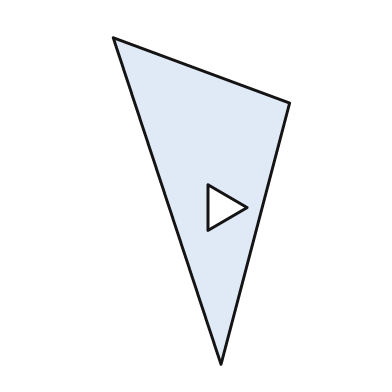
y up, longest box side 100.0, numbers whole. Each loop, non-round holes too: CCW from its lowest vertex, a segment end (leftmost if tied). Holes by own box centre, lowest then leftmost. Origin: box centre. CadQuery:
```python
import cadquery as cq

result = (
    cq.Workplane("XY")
    .moveTo(6.0, -50.0)
    .lineTo(27.0, 30.0)
    .lineTo(-27.0, 50.0)
    .close()
    .moveTo(2.0, -9.0)
    .lineTo(14.0, -2.0)
    .lineTo(2.0, 5.0)
    .close()
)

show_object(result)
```